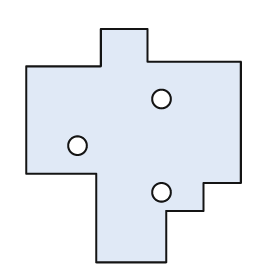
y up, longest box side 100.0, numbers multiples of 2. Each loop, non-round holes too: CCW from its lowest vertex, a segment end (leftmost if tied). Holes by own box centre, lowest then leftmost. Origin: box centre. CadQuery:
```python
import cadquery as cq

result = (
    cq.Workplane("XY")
    .moveTo(-16.0, -50.0)
    .lineTo(14.0, -50.0)
    .lineTo(14.0, -28.0)
    .lineTo(30.0, -28.0)
    .lineTo(30.0, -16.0)
    .lineTo(46.0, -16.0)
    .lineTo(46.0, 36.0)
    .lineTo(6.0, 36.0)
    .lineTo(6.0, 50.0)
    .lineTo(-14.0, 50.0)
    .lineTo(-14.0, 34.0)
    .lineTo(-46.0, 34.0)
    .lineTo(-46.0, -12.0)
    .lineTo(-16.0, -12.0)
    .close()
    .moveTo(12.0, -20.0)
    .circle(4.0)
    .moveTo(-24.0, 0.0)
    .circle(4.0)
    .moveTo(12.0, 20.0)
    .circle(4.0)
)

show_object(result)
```